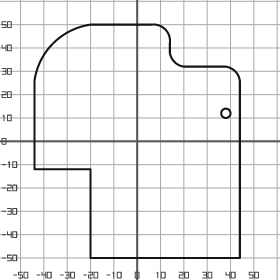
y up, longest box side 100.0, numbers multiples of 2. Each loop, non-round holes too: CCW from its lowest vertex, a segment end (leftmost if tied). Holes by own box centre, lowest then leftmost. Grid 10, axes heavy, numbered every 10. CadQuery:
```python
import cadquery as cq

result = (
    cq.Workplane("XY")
    .moveTo(-20.0, -50.0)
    .lineTo(44.0, -50.0)
    .lineTo(44.0, 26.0)
    .threePointArc((42.0, 30.0), (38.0, 32.0))
    .lineTo(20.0, 32.0)
    .threePointArc((16.0, 34.0), (14.0, 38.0))
    .lineTo(14.0, 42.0)
    .threePointArc((12.0, 48.0), (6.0, 50.0))
    .lineTo(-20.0, 50.0)
    .threePointArc((-36.0, 42.0), (-44.0, 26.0))
    .lineTo(-44.0, -12.0)
    .lineTo(-20.0, -12.0)
    .close()
    .moveTo(38.0, 12.0)
    .circle(2.0)
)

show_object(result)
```